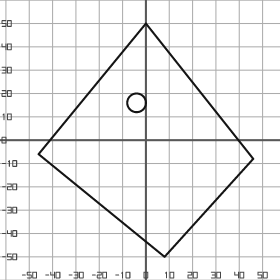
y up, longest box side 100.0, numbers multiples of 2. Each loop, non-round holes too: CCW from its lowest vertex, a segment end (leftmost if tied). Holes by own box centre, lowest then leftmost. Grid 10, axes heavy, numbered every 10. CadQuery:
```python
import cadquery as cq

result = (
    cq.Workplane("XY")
    .moveTo(8.0, -50.0)
    .lineTo(46.0, -8.0)
    .lineTo(0.0, 50.0)
    .lineTo(-46.0, -6.0)
    .close()
    .moveTo(-4.0, 16.0)
    .circle(4.0)
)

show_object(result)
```